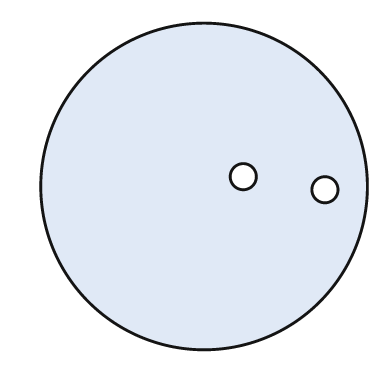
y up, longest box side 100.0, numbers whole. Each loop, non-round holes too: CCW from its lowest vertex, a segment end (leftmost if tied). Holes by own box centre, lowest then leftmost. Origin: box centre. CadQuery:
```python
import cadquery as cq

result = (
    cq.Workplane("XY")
    .moveTo(0.0, 0.0)
    .circle(50.0)
    .moveTo(37.0, -1.0)
    .circle(4.0)
    .moveTo(12.0, 3.0)
    .circle(4.0)
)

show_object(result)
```